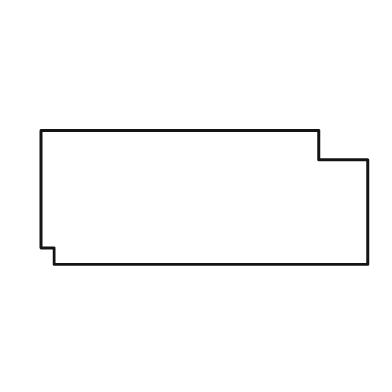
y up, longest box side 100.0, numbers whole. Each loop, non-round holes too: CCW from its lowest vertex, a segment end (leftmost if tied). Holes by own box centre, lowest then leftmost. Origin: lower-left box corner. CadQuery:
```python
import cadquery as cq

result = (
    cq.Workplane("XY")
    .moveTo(4.0, 0.0)
    .lineTo(100.0, 0.0)
    .lineTo(100.0, 32.0)
    .lineTo(85.0, 32.0)
    .lineTo(85.0, 41.0)
    .lineTo(0.0, 41.0)
    .lineTo(0.0, 5.0)
    .lineTo(4.0, 5.0)
    .close()
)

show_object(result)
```